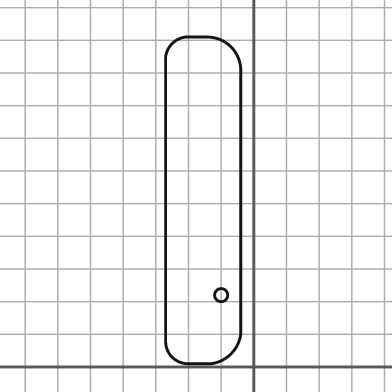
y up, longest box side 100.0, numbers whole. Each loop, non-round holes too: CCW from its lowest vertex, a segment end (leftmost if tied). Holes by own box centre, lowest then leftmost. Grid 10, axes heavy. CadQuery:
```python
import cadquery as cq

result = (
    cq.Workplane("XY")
    .moveTo(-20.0, 1.0)
    .lineTo(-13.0, 1.0)
    .threePointArc((-7.0, 4.0), (-4.0, 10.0))
    .lineTo(-4.0, 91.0)
    .threePointArc((-7.0, 98.0), (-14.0, 101.0))
    .lineTo(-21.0, 101.0)
    .threePointArc((-25.0, 99.0), (-27.0, 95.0))
    .lineTo(-27.0, 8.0)
    .threePointArc((-25.0, 3.0), (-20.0, 1.0))
    .close()
    .moveTo(-10.0, 22.0)
    .circle(2.0)
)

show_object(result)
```